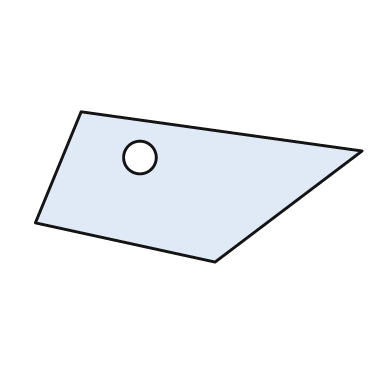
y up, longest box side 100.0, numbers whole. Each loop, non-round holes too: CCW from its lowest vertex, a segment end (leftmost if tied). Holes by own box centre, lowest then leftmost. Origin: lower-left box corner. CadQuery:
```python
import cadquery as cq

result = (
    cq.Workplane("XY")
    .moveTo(55.0, 0.0)
    .lineTo(100.0, 34.0)
    .lineTo(14.0, 46.0)
    .lineTo(0.0, 12.0)
    .close()
    .moveTo(32.0, 32.0)
    .circle(5.0)
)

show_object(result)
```